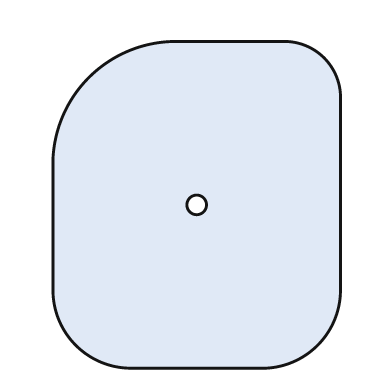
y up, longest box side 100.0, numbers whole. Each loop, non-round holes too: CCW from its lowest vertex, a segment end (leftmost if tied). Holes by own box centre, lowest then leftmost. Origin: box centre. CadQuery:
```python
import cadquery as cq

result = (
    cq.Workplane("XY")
    .moveTo(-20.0, -50.0)
    .lineTo(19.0, -50.0)
    .threePointArc((37.0, -43.0), (44.0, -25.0))
    .lineTo(44.0, 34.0)
    .threePointArc((39.0, 45.0), (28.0, 50.0))
    .lineTo(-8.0, 50.0)
    .threePointArc((-33.0, 39.0), (-44.0, 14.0))
    .lineTo(-44.0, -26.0)
    .threePointArc((-37.0, -43.0), (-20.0, -50.0))
    .close()
    .moveTo(0.0, 0.0)
    .circle(3.0)
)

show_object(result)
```